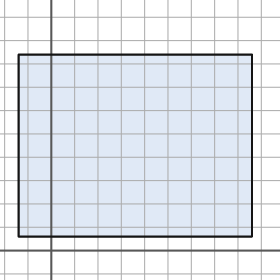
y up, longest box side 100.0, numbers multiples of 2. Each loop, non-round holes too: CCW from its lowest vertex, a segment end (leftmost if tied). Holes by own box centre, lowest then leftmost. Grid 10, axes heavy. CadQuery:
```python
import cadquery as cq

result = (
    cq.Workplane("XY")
    .moveTo(-14.0, 6.0)
    .lineTo(86.0, 6.0)
    .lineTo(86.0, 84.0)
    .lineTo(-14.0, 84.0)
    .close()
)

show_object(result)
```